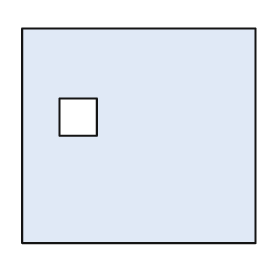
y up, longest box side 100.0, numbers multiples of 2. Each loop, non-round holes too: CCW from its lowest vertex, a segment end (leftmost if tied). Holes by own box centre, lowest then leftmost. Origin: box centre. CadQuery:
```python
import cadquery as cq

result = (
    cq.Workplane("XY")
    .moveTo(-50.0, -46.0)
    .lineTo(50.0, -46.0)
    .lineTo(50.0, 46.0)
    .lineTo(-50.0, 46.0)
    .close()
    .moveTo(-34.0, 0.0)
    .lineTo(-18.0, 0.0)
    .lineTo(-18.0, 16.0)
    .lineTo(-34.0, 16.0)
    .close()
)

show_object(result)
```